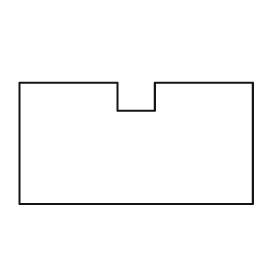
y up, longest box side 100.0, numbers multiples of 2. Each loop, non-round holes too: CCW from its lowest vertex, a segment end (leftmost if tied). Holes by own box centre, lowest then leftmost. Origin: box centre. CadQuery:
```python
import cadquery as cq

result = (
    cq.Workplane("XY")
    .moveTo(-50.0, -26.0)
    .lineTo(50.0, -26.0)
    .lineTo(50.0, 26.0)
    .lineTo(8.0, 26.0)
    .lineTo(8.0, 14.0)
    .lineTo(-8.0, 14.0)
    .lineTo(-8.0, 26.0)
    .lineTo(-50.0, 26.0)
    .close()
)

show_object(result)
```